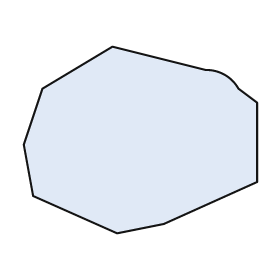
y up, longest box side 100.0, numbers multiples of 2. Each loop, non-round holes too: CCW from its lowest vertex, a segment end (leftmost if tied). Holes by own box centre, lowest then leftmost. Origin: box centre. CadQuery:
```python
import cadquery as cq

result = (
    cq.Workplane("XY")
    .moveTo(-10.0, -40.0)
    .lineTo(10.0, -36.0)
    .lineTo(50.0, -18.0)
    .lineTo(50.0, 16.0)
    .lineTo(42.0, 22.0)
    .threePointArc((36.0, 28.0), (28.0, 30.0))
    .lineTo(-12.0, 40.0)
    .lineTo(-42.0, 22.0)
    .lineTo(-50.0, -2.0)
    .lineTo(-46.0, -24.0)
    .close()
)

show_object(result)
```